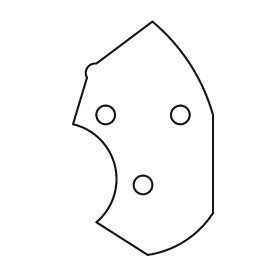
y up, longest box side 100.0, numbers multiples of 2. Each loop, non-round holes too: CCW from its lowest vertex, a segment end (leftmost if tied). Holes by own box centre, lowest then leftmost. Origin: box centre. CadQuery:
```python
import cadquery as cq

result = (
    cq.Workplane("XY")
    .moveTo(2.0, -50.0)
    .threePointArc((18.0, -44.0), (30.0, -32.0))
    .lineTo(30.0, 10.0)
    .threePointArc((20.0, 32.0), (4.0, 50.0))
    .lineTo(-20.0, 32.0)
    .threePointArc((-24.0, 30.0), (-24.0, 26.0))
    .lineTo(-30.0, 6.0)
    .threePointArc((-12.0, -12.0), (-20.0, -36.0))
    .close()
    .moveTo(0.0, -20.0)
    .circle(4.0)
    .moveTo(-16.0, 10.0)
    .circle(4.0)
    .moveTo(16.0, 10.0)
    .circle(4.0)
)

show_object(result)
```